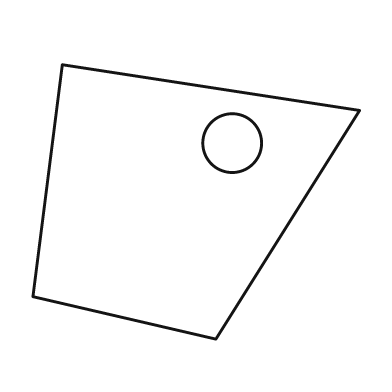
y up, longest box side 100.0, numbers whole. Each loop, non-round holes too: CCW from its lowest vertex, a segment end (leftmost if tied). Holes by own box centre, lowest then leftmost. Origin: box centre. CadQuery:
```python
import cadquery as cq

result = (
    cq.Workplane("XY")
    .moveTo(6.0, -42.0)
    .lineTo(50.0, 28.0)
    .lineTo(-41.0, 42.0)
    .lineTo(-50.0, -29.0)
    .close()
    .moveTo(11.0, 18.0)
    .circle(9.0)
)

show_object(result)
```